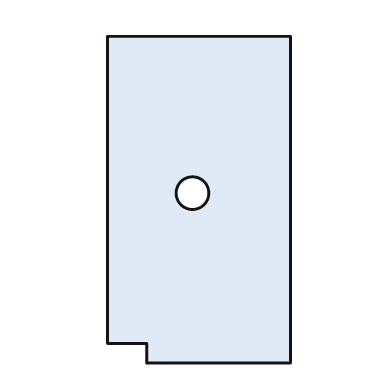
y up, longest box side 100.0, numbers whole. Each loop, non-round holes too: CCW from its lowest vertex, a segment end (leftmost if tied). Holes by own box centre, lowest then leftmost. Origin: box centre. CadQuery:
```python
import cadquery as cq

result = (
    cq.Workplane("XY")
    .moveTo(-16.0, -50.0)
    .lineTo(28.0, -50.0)
    .lineTo(28.0, 50.0)
    .lineTo(-28.0, 50.0)
    .lineTo(-28.0, -44.0)
    .lineTo(-16.0, -44.0)
    .close()
    .moveTo(-2.0, 2.0)
    .circle(5.0)
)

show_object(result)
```